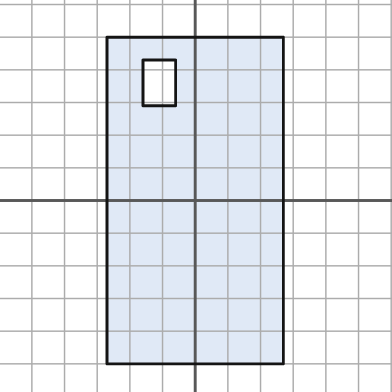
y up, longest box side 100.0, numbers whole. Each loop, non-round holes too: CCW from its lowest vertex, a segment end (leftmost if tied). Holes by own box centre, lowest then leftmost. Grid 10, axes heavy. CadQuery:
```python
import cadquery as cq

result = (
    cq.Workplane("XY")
    .moveTo(-27.0, -50.0)
    .lineTo(27.0, -50.0)
    .lineTo(27.0, 50.0)
    .lineTo(-27.0, 50.0)
    .close()
    .moveTo(-16.0, 29.0)
    .lineTo(-6.0, 29.0)
    .lineTo(-6.0, 43.0)
    .lineTo(-16.0, 43.0)
    .close()
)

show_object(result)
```